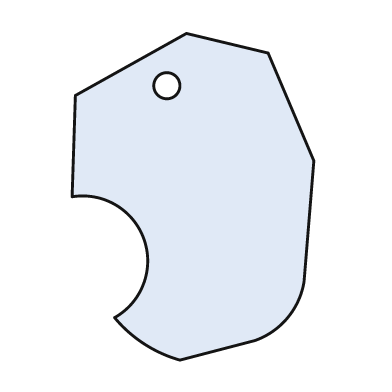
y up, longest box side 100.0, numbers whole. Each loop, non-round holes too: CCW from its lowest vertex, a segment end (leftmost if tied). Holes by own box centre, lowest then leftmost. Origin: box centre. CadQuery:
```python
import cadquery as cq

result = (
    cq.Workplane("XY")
    .moveTo(-4.0, -50.0)
    .lineTo(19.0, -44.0)
    .threePointArc((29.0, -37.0), (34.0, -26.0))
    .lineTo(37.0, 11.0)
    .lineTo(23.0, 44.0)
    .lineTo(-2.0, 50.0)
    .lineTo(-36.0, 31.0)
    .lineTo(-37.0, 0.0)
    .threePointArc((-15.0, -13.0), (-24.0, -37.0))
    .threePointArc((-15.0, -45.0), (-4.0, -50.0))
    .close()
    .moveTo(-8.0, 34.0)
    .circle(4.0)
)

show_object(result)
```